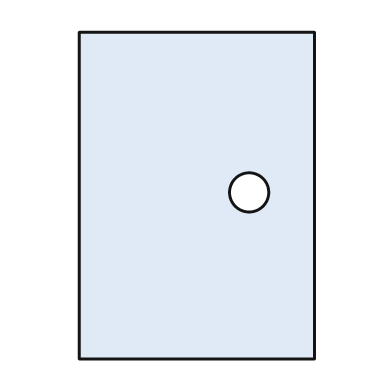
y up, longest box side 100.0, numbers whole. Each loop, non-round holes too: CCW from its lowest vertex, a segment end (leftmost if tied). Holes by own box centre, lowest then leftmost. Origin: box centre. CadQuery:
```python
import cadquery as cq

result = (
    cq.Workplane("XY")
    .moveTo(-36.0, -50.0)
    .lineTo(36.0, -50.0)
    .lineTo(36.0, 50.0)
    .lineTo(-36.0, 50.0)
    .close()
    .moveTo(16.0, 1.0)
    .circle(6.0)
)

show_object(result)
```